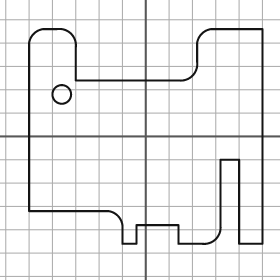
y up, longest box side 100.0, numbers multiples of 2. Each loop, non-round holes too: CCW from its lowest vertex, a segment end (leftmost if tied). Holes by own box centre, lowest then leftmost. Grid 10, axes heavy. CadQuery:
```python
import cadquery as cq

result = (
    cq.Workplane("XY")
    .moveTo(-10.0, -46.0)
    .lineTo(-4.0, -46.0)
    .lineTo(-4.0, -38.0)
    .lineTo(14.0, -38.0)
    .lineTo(14.0, -46.0)
    .lineTo(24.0, -46.0)
    .threePointArc((30.0, -44.0), (32.0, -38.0))
    .lineTo(32.0, -10.0)
    .lineTo(40.0, -10.0)
    .lineTo(40.0, -46.0)
    .lineTo(50.0, -46.0)
    .lineTo(50.0, 46.0)
    .lineTo(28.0, 46.0)
    .threePointArc((24.0, 44.0), (22.0, 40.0))
    .lineTo(22.0, 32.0)
    .threePointArc((20.0, 26.0), (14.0, 24.0))
    .lineTo(-30.0, 24.0)
    .lineTo(-30.0, 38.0)
    .threePointArc((-32.0, 44.0), (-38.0, 46.0))
    .lineTo(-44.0, 46.0)
    .threePointArc((-48.0, 44.0), (-50.0, 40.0))
    .lineTo(-50.0, -32.0)
    .lineTo(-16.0, -32.0)
    .threePointArc((-12.0, -34.0), (-10.0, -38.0))
    .close()
    .moveTo(-36.0, 18.0)
    .circle(4.0)
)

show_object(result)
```